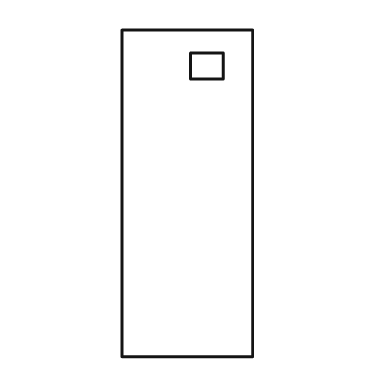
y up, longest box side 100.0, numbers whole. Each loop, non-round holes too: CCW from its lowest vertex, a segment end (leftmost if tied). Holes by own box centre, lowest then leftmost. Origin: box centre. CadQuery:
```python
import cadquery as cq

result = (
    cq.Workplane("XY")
    .moveTo(-20.0, -50.0)
    .lineTo(20.0, -50.0)
    .lineTo(20.0, 50.0)
    .lineTo(-20.0, 50.0)
    .close()
    .moveTo(1.0, 35.0)
    .lineTo(11.0, 35.0)
    .lineTo(11.0, 43.0)
    .lineTo(1.0, 43.0)
    .close()
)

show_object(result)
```